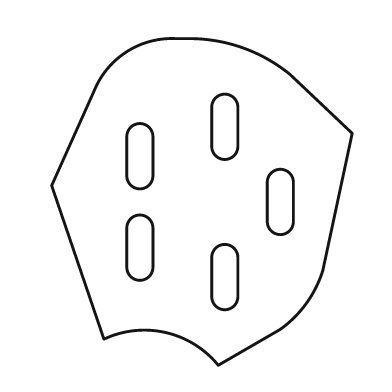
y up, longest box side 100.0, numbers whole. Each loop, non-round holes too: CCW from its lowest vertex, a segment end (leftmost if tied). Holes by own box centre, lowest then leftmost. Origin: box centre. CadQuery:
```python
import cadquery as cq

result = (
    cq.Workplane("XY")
    .moveTo(5.0, -50.0)
    .lineTo(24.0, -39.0)
    .threePointArc((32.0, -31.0), (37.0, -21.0))
    .lineTo(46.0, 21.0)
    .lineTo(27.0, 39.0)
    .threePointArc((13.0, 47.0), (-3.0, 50.0))
    .lineTo(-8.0, 50.0)
    .threePointArc((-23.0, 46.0), (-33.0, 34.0))
    .lineTo(-46.0, 5.0)
    .lineTo(-30.0, -42.0)
    .threePointArc((-11.0, -40.0), (5.0, -50.0))
    .close()
    .moveTo(3.0, -29.0)
    .threePointArc((7.0, -33.0), (11.0, -29.0))
    .lineTo(11.0, -17.0)
    .threePointArc((7.0, -13.0), (3.0, -17.0))
    .close()
    .moveTo(-23.0, -20.0)
    .threePointArc((-19.0, -24.0), (-15.0, -20.0))
    .lineTo(-15.0, -8.0)
    .threePointArc((-19.0, -4.0), (-23.0, -8.0))
    .close()
    .moveTo(20.0, -6.0)
    .threePointArc((24.0, -10.0), (28.0, -6.0))
    .lineTo(28.0, 6.0)
    .threePointArc((24.0, 10.0), (20.0, 6.0))
    .close()
    .moveTo(-23.0, 8.0)
    .threePointArc((-19.0, 4.0), (-15.0, 8.0))
    .lineTo(-15.0, 20.0)
    .threePointArc((-19.0, 24.0), (-23.0, 20.0))
    .close()
    .moveTo(3.0, 17.0)
    .threePointArc((7.0, 13.0), (11.0, 17.0))
    .lineTo(11.0, 29.0)
    .threePointArc((7.0, 33.0), (3.0, 29.0))
    .close()
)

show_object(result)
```